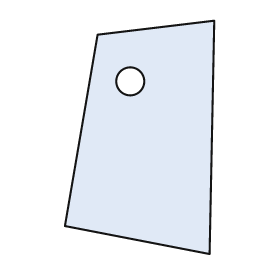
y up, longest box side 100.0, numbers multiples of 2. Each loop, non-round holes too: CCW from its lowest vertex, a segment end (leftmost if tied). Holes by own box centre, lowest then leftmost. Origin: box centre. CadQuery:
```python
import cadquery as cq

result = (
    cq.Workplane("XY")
    .moveTo(30.0, -50.0)
    .lineTo(32.0, 50.0)
    .lineTo(-18.0, 44.0)
    .lineTo(-32.0, -38.0)
    .close()
    .moveTo(-4.0, 24.0)
    .circle(6.0)
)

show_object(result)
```